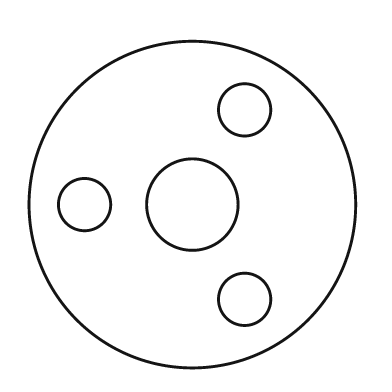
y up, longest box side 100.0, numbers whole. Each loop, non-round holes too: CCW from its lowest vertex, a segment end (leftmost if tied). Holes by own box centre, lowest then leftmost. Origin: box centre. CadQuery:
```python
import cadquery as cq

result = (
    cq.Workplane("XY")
    .moveTo(0.0, 0.0)
    .circle(50.0)
    .moveTo(16.0, -29.0)
    .circle(8.0)
    .moveTo(-33.0, 0.0)
    .circle(8.0)
    .moveTo(0.0, 0.0)
    .circle(14.0)
    .moveTo(16.0, 29.0)
    .circle(8.0)
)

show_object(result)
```